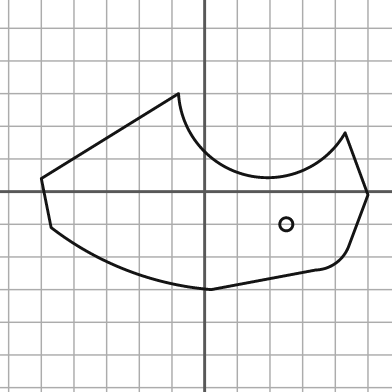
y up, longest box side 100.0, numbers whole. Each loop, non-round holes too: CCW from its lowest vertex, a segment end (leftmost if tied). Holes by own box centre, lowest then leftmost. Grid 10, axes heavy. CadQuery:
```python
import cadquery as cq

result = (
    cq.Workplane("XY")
    .moveTo(2.0, -30.0)
    .lineTo(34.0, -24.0)
    .threePointArc((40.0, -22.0), (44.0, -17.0))
    .lineTo(50.0, -1.0)
    .lineTo(43.0, 18.0)
    .threePointArc((13.0, 5.0), (-8.0, 30.0))
    .lineTo(-50.0, 4.0)
    .lineTo(-47.0, -11.0)
    .threePointArc((-24.0, -24.0), (2.0, -30.0))
    .close()
    .moveTo(25.0, -10.0)
    .circle(2.0)
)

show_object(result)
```